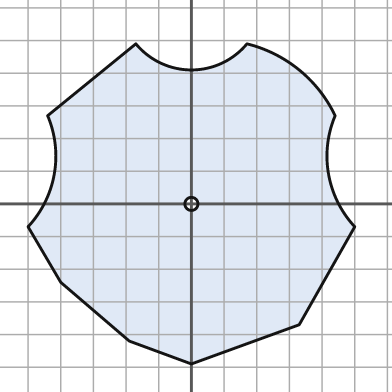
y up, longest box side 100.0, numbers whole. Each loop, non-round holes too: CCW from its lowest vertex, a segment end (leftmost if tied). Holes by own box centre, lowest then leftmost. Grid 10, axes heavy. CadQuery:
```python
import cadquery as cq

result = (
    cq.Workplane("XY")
    .moveTo(0.0, -49.0)
    .lineTo(33.0, -37.0)
    .lineTo(50.0, -7.0)
    .threePointArc((42.0, 9.0), (44.0, 27.0))
    .threePointArc((33.0, 41.0), (17.0, 49.0))
    .threePointArc((0.0, 41.0), (-17.0, 49.0))
    .lineTo(-44.0, 27.0)
    .threePointArc((-42.0, 9.0), (-50.0, -7.0))
    .lineTo(-40.0, -24.0)
    .lineTo(-19.0, -42.0)
    .close()
    .moveTo(0.0, 0.0)
    .circle(2.0)
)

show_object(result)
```